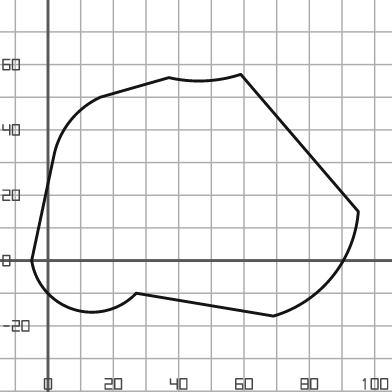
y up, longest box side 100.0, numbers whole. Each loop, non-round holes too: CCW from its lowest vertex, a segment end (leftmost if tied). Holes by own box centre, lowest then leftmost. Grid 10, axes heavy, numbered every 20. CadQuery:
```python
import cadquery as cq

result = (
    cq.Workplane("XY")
    .moveTo(69.0, -17.0)
    .threePointArc((87.0, -5.0), (95.0, 15.0))
    .lineTo(59.0, 57.0)
    .threePointArc((48.0, 55.0), (37.0, 56.0))
    .lineTo(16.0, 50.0)
    .threePointArc((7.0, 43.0), (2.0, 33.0))
    .lineTo(-5.0, 0.0)
    .threePointArc((8.0, -15.0), (27.0, -10.0))
    .close()
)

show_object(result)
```